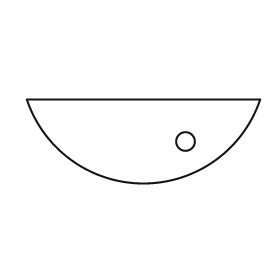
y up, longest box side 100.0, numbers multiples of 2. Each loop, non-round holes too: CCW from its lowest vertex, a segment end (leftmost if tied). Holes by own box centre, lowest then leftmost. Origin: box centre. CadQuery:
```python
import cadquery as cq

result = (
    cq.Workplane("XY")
    .moveTo(-50.0, 18.0)
    .threePointArc((0.0, -18.0), (50.0, 18.0))
    .close()
    .moveTo(18.0, 0.0)
    .circle(4.0)
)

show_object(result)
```